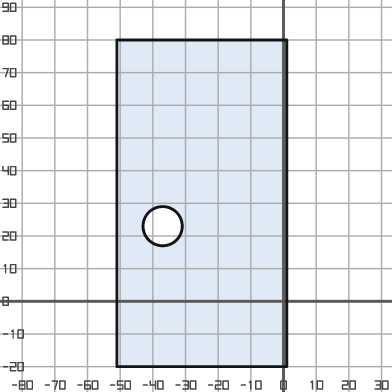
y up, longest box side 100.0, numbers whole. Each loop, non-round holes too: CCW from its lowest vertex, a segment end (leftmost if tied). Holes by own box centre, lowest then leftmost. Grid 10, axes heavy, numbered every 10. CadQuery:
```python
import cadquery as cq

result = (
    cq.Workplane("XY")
    .moveTo(-51.0, -20.0)
    .lineTo(1.0, -20.0)
    .lineTo(1.0, 80.0)
    .lineTo(-51.0, 80.0)
    .close()
    .moveTo(-37.0, 23.0)
    .circle(6.0)
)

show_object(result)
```